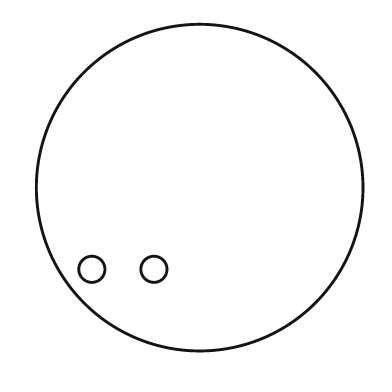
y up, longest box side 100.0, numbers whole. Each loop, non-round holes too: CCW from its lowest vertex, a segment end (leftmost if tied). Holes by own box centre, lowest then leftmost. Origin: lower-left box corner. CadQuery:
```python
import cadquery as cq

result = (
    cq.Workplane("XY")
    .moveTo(50.0, 50.0)
    .circle(50.0)
    .moveTo(17.0, 25.0)
    .circle(4.0)
    .moveTo(36.0, 25.0)
    .circle(4.0)
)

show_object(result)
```